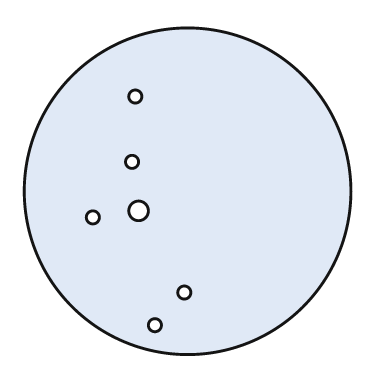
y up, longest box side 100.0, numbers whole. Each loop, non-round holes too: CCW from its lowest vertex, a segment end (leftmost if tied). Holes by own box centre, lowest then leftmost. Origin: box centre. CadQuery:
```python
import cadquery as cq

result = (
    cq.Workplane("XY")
    .moveTo(0.0, 0.0)
    .circle(50.0)
    .moveTo(-10.0, -41.0)
    .circle(2.0)
    .moveTo(-1.0, -31.0)
    .circle(2.0)
    .moveTo(-29.0, -8.0)
    .circle(2.0)
    .moveTo(-15.0, -6.0)
    .circle(3.0)
    .moveTo(-17.0, 9.0)
    .circle(2.0)
    .moveTo(-16.0, 29.0)
    .circle(2.0)
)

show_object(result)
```